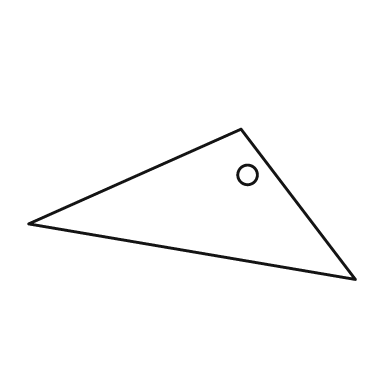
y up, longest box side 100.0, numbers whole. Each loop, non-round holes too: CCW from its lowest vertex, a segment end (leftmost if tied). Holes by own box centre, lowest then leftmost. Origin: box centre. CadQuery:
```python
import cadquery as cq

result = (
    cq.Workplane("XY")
    .moveTo(50.0, -23.0)
    .lineTo(15.0, 23.0)
    .lineTo(-50.0, -6.0)
    .close()
    .moveTo(17.0, 9.0)
    .circle(3.0)
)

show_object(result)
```